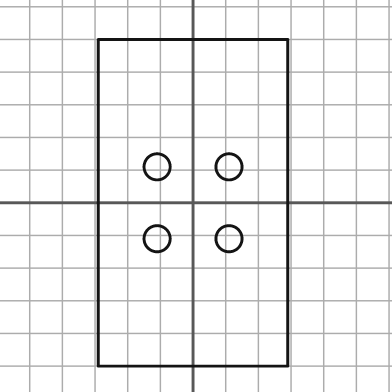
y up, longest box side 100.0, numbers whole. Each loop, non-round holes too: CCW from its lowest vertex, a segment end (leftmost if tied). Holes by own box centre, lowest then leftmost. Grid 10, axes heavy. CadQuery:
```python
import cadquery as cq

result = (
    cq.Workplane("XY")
    .moveTo(-29.0, -50.0)
    .lineTo(29.0, -50.0)
    .lineTo(29.0, 50.0)
    .lineTo(-29.0, 50.0)
    .close()
    .moveTo(-11.0, -11.0)
    .circle(4.0)
    .moveTo(11.0, -11.0)
    .circle(4.0)
    .moveTo(-11.0, 11.0)
    .circle(4.0)
    .moveTo(11.0, 11.0)
    .circle(4.0)
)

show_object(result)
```